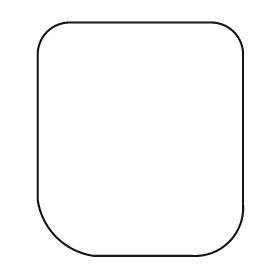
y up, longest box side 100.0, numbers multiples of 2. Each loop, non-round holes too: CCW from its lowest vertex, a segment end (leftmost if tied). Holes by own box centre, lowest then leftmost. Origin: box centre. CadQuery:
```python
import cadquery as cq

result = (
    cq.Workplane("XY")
    .moveTo(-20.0, -50.0)
    .lineTo(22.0, -50.0)
    .threePointArc((38.0, -44.0), (44.0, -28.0))
    .lineTo(44.0, 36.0)
    .threePointArc((40.0, 46.0), (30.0, 50.0))
    .lineTo(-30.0, 50.0)
    .threePointArc((-40.0, 46.0), (-44.0, 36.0))
    .lineTo(-44.0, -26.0)
    .threePointArc((-36.0, -42.0), (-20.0, -50.0))
    .close()
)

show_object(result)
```